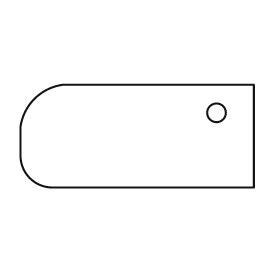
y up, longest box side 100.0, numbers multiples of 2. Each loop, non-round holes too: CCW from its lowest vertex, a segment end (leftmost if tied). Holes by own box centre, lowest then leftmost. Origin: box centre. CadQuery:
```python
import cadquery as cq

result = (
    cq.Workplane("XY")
    .moveTo(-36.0, -22.0)
    .lineTo(50.0, -22.0)
    .lineTo(50.0, 22.0)
    .lineTo(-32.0, 22.0)
    .threePointArc((-44.0, 16.0), (-50.0, 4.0))
    .lineTo(-50.0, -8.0)
    .threePointArc((-46.0, -18.0), (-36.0, -22.0))
    .close()
    .moveTo(34.0, 10.0)
    .circle(4.0)
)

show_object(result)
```